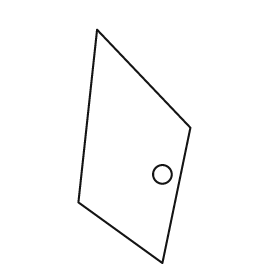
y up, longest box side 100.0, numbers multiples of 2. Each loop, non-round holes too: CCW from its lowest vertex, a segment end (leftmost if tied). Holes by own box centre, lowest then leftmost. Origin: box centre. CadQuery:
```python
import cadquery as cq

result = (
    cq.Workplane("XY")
    .moveTo(12.0, -50.0)
    .lineTo(24.0, 8.0)
    .lineTo(-16.0, 50.0)
    .lineTo(-24.0, -24.0)
    .close()
    .moveTo(12.0, -12.0)
    .circle(4.0)
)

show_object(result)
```